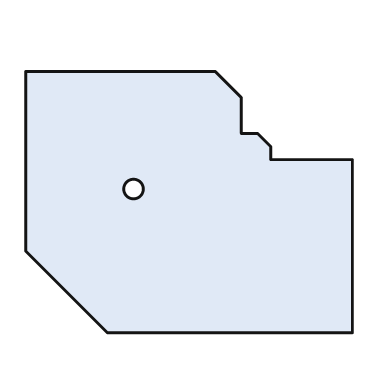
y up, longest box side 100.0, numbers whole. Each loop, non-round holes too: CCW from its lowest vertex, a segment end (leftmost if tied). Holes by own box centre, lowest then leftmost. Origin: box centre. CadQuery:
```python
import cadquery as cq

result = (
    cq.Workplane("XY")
    .moveTo(-25.0, -40.0)
    .lineTo(50.0, -40.0)
    .lineTo(50.0, 13.0)
    .lineTo(25.0, 13.0)
    .lineTo(25.0, 17.0)
    .lineTo(21.0, 21.0)
    .lineTo(16.0, 21.0)
    .lineTo(16.0, 32.0)
    .lineTo(8.0, 40.0)
    .lineTo(-50.0, 40.0)
    .lineTo(-50.0, -15.0)
    .close()
    .moveTo(-17.0, 4.0)
    .circle(3.0)
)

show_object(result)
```